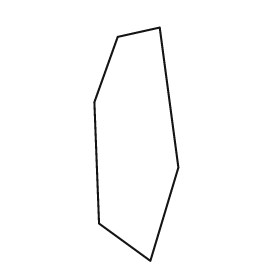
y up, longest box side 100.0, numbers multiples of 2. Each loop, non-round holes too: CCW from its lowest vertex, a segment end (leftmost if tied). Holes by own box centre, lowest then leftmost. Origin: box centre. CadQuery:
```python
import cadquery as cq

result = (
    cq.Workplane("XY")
    .moveTo(6.0, -50.0)
    .lineTo(18.0, -10.0)
    .lineTo(10.0, 50.0)
    .lineTo(-8.0, 46.0)
    .lineTo(-18.0, 18.0)
    .lineTo(-16.0, -34.0)
    .close()
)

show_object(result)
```